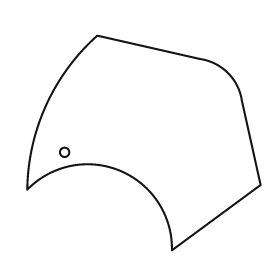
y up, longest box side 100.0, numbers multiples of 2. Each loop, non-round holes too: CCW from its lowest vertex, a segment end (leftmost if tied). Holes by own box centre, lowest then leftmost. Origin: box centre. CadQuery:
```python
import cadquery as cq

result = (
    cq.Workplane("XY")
    .moveTo(12.0, -46.0)
    .lineTo(50.0, -18.0)
    .lineTo(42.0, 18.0)
    .threePointArc((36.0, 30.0), (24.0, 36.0))
    .lineTo(-20.0, 46.0)
    .threePointArc((-42.0, 16.0), (-50.0, -20.0))
    .threePointArc((-10.0, -12.0), (12.0, -46.0))
    .close()
    .moveTo(-34.0, -4.0)
    .circle(2.0)
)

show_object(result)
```